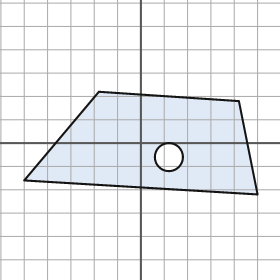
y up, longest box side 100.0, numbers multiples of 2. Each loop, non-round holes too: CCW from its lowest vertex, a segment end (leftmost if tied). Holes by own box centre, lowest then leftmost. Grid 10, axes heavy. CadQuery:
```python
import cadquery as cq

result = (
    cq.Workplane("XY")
    .moveTo(50.0, -22.0)
    .lineTo(42.0, 18.0)
    .lineTo(-18.0, 22.0)
    .lineTo(-50.0, -16.0)
    .close()
    .moveTo(12.0, -6.0)
    .circle(6.0)
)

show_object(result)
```